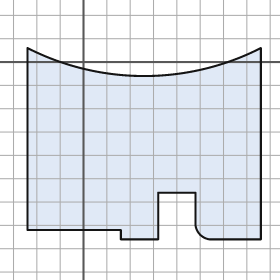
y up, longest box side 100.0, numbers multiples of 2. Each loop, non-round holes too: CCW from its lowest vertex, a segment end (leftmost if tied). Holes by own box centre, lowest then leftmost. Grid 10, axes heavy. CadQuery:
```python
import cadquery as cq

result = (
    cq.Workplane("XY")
    .moveTo(16.0, -76.0)
    .lineTo(32.0, -76.0)
    .lineTo(32.0, -56.0)
    .lineTo(48.0, -56.0)
    .lineTo(48.0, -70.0)
    .threePointArc((50.0, -74.0), (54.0, -76.0))
    .lineTo(76.0, -76.0)
    .lineTo(76.0, 6.0)
    .threePointArc((26.0, -6.0), (-24.0, 6.0))
    .lineTo(-24.0, -72.0)
    .lineTo(16.0, -72.0)
    .close()
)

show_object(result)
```